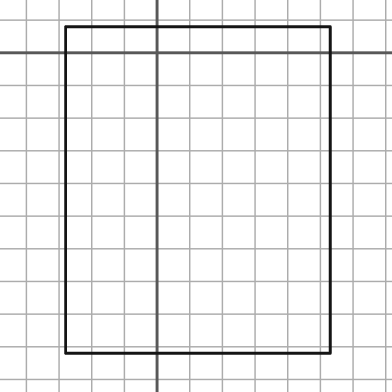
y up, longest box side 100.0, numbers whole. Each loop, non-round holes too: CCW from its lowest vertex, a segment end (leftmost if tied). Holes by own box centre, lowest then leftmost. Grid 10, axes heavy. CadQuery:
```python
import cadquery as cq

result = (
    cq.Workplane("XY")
    .moveTo(-28.0, -92.0)
    .lineTo(53.0, -92.0)
    .lineTo(53.0, 8.0)
    .lineTo(-28.0, 8.0)
    .close()
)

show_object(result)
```